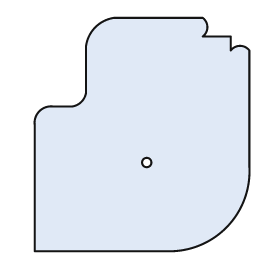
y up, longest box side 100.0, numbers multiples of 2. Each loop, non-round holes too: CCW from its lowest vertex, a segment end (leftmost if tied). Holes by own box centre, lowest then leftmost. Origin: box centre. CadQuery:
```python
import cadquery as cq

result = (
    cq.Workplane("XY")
    .moveTo(-46.0, -50.0)
    .lineTo(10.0, -50.0)
    .threePointArc((36.0, -40.0), (46.0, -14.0))
    .lineTo(46.0, 36.0)
    .threePointArc((42.0, 38.0), (38.0, 36.0))
    .lineTo(38.0, 42.0)
    .lineTo(26.0, 42.0)
    .threePointArc((28.0, 46.0), (26.0, 50.0))
    .lineTo(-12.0, 50.0)
    .threePointArc((-20.0, 46.0), (-24.0, 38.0))
    .lineTo(-24.0, 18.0)
    .threePointArc((-26.0, 14.0), (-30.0, 12.0))
    .lineTo(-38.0, 12.0)
    .threePointArc((-44.0, 10.0), (-46.0, 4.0))
    .close()
    .moveTo(2.0, -12.0)
    .circle(2.0)
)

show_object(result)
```